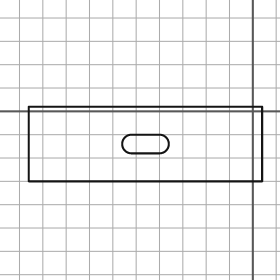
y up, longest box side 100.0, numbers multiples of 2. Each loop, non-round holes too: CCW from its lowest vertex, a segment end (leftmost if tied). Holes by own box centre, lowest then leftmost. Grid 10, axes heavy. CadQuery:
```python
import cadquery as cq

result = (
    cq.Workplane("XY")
    .moveTo(-96.0, -30.0)
    .lineTo(4.0, -30.0)
    .lineTo(4.0, 2.0)
    .lineTo(-96.0, 2.0)
    .close()
    .moveTo(-52.0, -18.0)
    .lineTo(-40.0, -18.0)
    .threePointArc((-36.0, -14.0), (-40.0, -10.0))
    .lineTo(-52.0, -10.0)
    .threePointArc((-56.0, -14.0), (-52.0, -18.0))
    .close()
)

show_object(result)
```